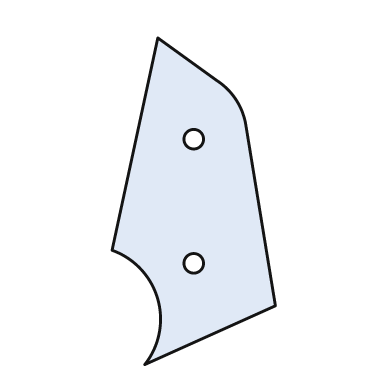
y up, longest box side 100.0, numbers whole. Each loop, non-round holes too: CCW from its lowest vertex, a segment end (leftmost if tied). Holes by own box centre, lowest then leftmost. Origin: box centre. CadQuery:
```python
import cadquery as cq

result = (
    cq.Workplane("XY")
    .moveTo(-15.0, -50.0)
    .lineTo(25.0, -32.0)
    .lineTo(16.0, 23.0)
    .threePointArc((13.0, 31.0), (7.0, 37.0))
    .lineTo(-11.0, 50.0)
    .lineTo(-25.0, -15.0)
    .threePointArc((-11.0, -30.0), (-15.0, -50.0))
    .close()
    .moveTo(0.0, -19.0)
    .circle(3.0)
    .moveTo(0.0, 19.0)
    .circle(3.0)
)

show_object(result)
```